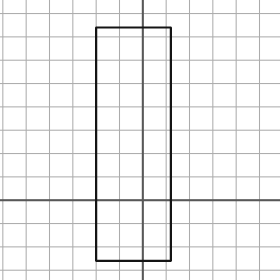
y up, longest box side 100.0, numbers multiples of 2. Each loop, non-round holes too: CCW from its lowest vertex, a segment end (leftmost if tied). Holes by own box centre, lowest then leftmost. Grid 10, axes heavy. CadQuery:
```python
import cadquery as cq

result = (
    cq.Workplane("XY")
    .moveTo(-20.0, -26.0)
    .lineTo(12.0, -26.0)
    .lineTo(12.0, 74.0)
    .lineTo(-20.0, 74.0)
    .close()
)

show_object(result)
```